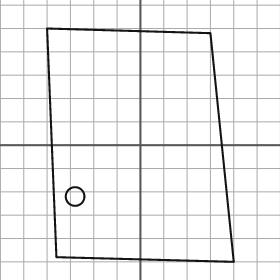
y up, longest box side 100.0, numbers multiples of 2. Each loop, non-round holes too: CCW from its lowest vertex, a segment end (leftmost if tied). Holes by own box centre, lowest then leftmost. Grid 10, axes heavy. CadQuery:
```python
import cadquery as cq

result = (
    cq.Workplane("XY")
    .moveTo(40.0, -50.0)
    .lineTo(30.0, 48.0)
    .lineTo(-40.0, 50.0)
    .lineTo(-36.0, -48.0)
    .close()
    .moveTo(-28.0, -22.0)
    .circle(4.0)
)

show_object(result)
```